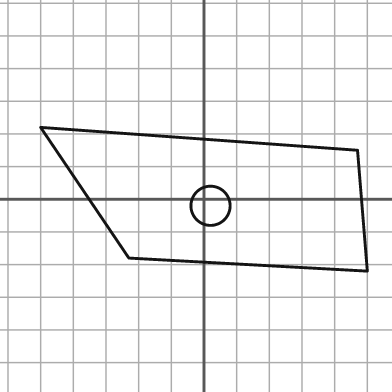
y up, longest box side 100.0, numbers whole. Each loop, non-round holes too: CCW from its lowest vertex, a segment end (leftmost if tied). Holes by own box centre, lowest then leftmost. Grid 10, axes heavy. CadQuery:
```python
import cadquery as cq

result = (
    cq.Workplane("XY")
    .moveTo(50.0, -22.0)
    .lineTo(47.0, 15.0)
    .lineTo(-50.0, 22.0)
    .lineTo(-23.0, -18.0)
    .close()
    .moveTo(2.0, -2.0)
    .circle(6.0)
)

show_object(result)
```